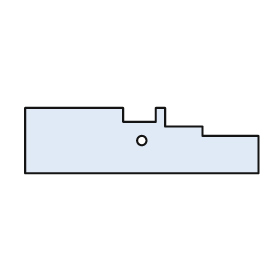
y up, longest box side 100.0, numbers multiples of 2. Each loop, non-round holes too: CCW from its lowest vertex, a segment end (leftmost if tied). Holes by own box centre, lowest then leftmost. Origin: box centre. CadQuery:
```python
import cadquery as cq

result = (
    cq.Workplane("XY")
    .moveTo(-50.0, -14.0)
    .lineTo(50.0, -14.0)
    .lineTo(50.0, 2.0)
    .lineTo(26.0, 2.0)
    .lineTo(26.0, 6.0)
    .lineTo(10.0, 6.0)
    .lineTo(10.0, 14.0)
    .lineTo(6.0, 14.0)
    .lineTo(6.0, 8.0)
    .lineTo(-8.0, 8.0)
    .lineTo(-8.0, 14.0)
    .lineTo(-50.0, 14.0)
    .close()
    .moveTo(0.0, 0.0)
    .circle(2.0)
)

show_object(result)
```